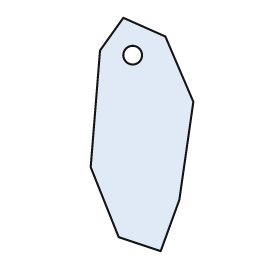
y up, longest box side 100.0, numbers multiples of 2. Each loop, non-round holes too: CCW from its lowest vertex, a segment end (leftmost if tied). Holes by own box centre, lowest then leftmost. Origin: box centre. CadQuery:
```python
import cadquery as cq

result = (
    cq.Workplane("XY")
    .moveTo(8.0, -50.0)
    .lineTo(16.0, -28.0)
    .lineTo(22.0, 14.0)
    .lineTo(10.0, 42.0)
    .lineTo(-8.0, 50.0)
    .lineTo(-18.0, 36.0)
    .lineTo(-22.0, -14.0)
    .lineTo(-10.0, -44.0)
    .close()
    .moveTo(-4.0, 34.0)
    .circle(4.0)
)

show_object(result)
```